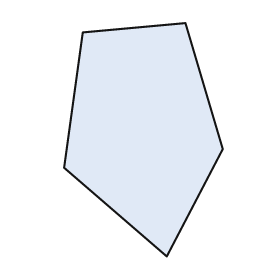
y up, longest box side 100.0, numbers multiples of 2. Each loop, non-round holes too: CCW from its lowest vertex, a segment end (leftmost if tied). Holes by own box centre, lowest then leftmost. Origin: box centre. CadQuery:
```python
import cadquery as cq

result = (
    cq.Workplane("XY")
    .moveTo(10.0, -50.0)
    .lineTo(34.0, -4.0)
    .lineTo(18.0, 50.0)
    .lineTo(-26.0, 46.0)
    .lineTo(-34.0, -12.0)
    .close()
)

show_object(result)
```